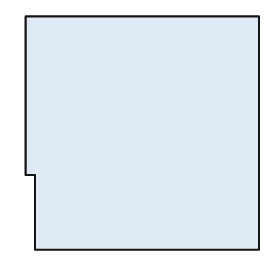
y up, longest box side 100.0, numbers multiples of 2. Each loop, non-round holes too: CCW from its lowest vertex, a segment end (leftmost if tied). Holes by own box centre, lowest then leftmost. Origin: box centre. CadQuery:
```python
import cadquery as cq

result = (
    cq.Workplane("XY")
    .moveTo(-46.0, -50.0)
    .lineTo(50.0, -50.0)
    .lineTo(50.0, 50.0)
    .lineTo(-50.0, 50.0)
    .lineTo(-50.0, -18.0)
    .lineTo(-46.0, -18.0)
    .close()
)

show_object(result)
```